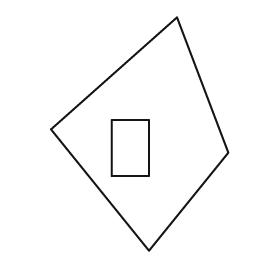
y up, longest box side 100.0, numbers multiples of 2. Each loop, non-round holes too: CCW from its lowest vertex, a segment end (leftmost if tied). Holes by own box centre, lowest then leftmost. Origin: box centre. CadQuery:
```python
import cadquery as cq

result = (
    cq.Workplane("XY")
    .moveTo(4.0, -50.0)
    .lineTo(38.0, -8.0)
    .lineTo(16.0, 50.0)
    .lineTo(-38.0, 2.0)
    .close()
    .moveTo(-12.0, -18.0)
    .lineTo(4.0, -18.0)
    .lineTo(4.0, 6.0)
    .lineTo(-12.0, 6.0)
    .close()
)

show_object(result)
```